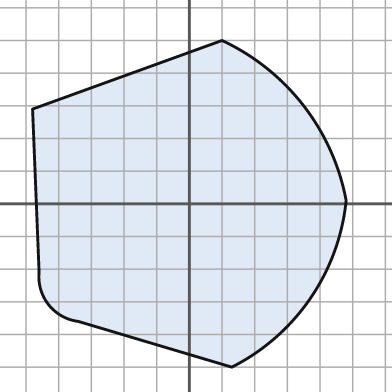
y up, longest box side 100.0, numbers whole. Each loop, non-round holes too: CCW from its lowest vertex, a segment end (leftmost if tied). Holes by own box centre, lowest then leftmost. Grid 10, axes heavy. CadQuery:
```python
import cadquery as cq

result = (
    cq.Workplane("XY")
    .moveTo(13.0, -50.0)
    .threePointArc((37.0, -29.0), (48.0, 1.0))
    .threePointArc((35.0, 30.0), (10.0, 50.0))
    .lineTo(-48.0, 29.0)
    .lineTo(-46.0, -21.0)
    .threePointArc((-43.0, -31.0), (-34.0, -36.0))
    .close()
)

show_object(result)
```